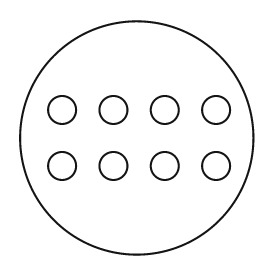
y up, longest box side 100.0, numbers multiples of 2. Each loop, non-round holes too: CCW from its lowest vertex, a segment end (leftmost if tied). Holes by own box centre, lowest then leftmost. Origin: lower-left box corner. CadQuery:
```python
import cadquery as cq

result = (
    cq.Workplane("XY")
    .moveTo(50.0, 50.0)
    .circle(50.0)
    .moveTo(18.0, 38.0)
    .circle(6.0)
    .moveTo(40.0, 38.0)
    .circle(6.0)
    .moveTo(62.0, 38.0)
    .circle(6.0)
    .moveTo(84.0, 38.0)
    .circle(6.0)
    .moveTo(18.0, 62.0)
    .circle(6.0)
    .moveTo(40.0, 62.0)
    .circle(6.0)
    .moveTo(62.0, 62.0)
    .circle(6.0)
    .moveTo(84.0, 62.0)
    .circle(6.0)
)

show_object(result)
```